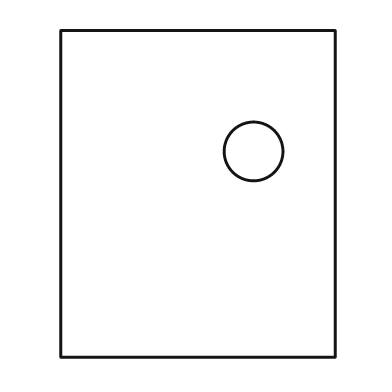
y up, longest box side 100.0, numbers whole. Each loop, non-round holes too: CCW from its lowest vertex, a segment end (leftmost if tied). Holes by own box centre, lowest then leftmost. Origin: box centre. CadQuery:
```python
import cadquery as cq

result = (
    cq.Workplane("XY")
    .moveTo(-42.0, -50.0)
    .lineTo(42.0, -50.0)
    .lineTo(42.0, 50.0)
    .lineTo(-42.0, 50.0)
    .close()
    .moveTo(17.0, 13.0)
    .circle(9.0)
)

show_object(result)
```